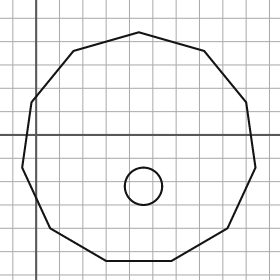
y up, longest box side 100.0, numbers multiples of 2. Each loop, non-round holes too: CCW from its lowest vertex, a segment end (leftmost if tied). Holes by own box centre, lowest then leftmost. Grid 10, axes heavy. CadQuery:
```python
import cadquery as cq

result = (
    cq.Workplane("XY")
    .moveTo(30.0, -54.0)
    .lineTo(58.0, -54.0)
    .lineTo(82.0, -40.0)
    .lineTo(94.0, -14.0)
    .lineTo(90.0, 14.0)
    .lineTo(72.0, 36.0)
    .lineTo(44.0, 44.0)
    .lineTo(16.0, 36.0)
    .lineTo(-2.0, 14.0)
    .lineTo(-6.0, -14.0)
    .lineTo(6.0, -40.0)
    .close()
    .moveTo(46.0, -22.0)
    .circle(8.0)
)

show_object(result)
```